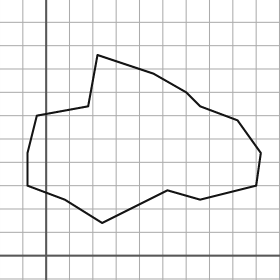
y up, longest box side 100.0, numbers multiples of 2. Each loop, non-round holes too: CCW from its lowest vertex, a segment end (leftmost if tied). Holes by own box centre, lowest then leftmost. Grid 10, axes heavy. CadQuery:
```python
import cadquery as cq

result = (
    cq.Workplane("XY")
    .moveTo(24.0, 14.0)
    .lineTo(52.0, 28.0)
    .lineTo(66.0, 24.0)
    .lineTo(90.0, 30.0)
    .lineTo(92.0, 44.0)
    .lineTo(82.0, 58.0)
    .lineTo(66.0, 64.0)
    .lineTo(60.0, 70.0)
    .lineTo(46.0, 78.0)
    .lineTo(22.0, 86.0)
    .lineTo(18.0, 64.0)
    .lineTo(-4.0, 60.0)
    .lineTo(-8.0, 44.0)
    .lineTo(-8.0, 30.0)
    .lineTo(8.0, 24.0)
    .close()
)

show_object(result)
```